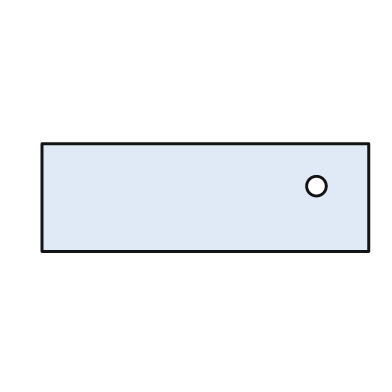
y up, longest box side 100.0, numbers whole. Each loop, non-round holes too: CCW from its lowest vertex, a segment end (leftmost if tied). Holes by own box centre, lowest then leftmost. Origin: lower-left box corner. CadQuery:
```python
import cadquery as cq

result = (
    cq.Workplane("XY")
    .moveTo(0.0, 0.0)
    .lineTo(100.0, 0.0)
    .lineTo(100.0, 33.0)
    .lineTo(0.0, 33.0)
    .close()
    .moveTo(84.0, 20.0)
    .circle(3.0)
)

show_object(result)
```